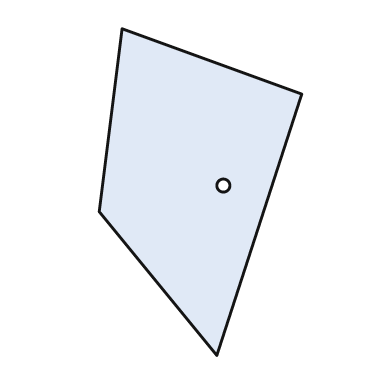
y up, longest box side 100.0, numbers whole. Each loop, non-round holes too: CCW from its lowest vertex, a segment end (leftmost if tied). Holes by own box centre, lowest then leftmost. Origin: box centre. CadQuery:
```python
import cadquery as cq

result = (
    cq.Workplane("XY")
    .moveTo(5.0, -50.0)
    .lineTo(31.0, 30.0)
    .lineTo(-24.0, 50.0)
    .lineTo(-31.0, -6.0)
    .close()
    .moveTo(7.0, 2.0)
    .circle(2.0)
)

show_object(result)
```